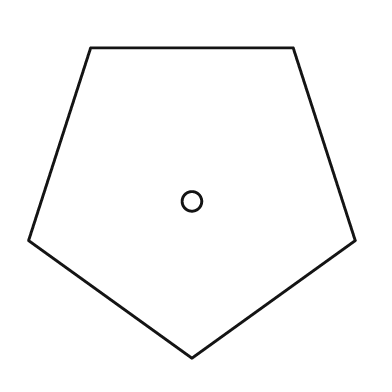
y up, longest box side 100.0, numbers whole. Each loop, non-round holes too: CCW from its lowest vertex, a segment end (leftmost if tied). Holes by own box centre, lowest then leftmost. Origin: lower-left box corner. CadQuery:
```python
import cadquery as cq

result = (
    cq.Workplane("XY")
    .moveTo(50.0, 0.0)
    .lineTo(100.0, 36.0)
    .lineTo(81.0, 95.0)
    .lineTo(19.0, 95.0)
    .lineTo(0.0, 36.0)
    .close()
    .moveTo(50.0, 48.0)
    .circle(3.0)
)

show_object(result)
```